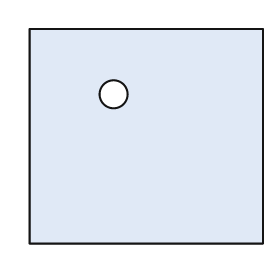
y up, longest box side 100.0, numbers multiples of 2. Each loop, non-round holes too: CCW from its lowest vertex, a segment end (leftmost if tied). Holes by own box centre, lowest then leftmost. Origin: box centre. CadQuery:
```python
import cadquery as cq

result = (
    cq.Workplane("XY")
    .moveTo(-50.0, -46.0)
    .lineTo(50.0, -46.0)
    .lineTo(50.0, 46.0)
    .lineTo(-50.0, 46.0)
    .close()
    .moveTo(-14.0, 18.0)
    .circle(6.0)
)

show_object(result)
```